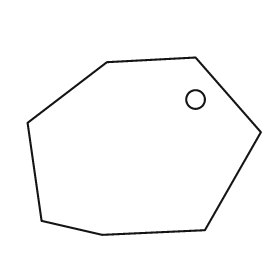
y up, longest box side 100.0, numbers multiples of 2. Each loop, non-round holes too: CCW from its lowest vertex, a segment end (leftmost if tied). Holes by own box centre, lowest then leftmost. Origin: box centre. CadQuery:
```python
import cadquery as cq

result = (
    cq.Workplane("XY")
    .moveTo(-18.0, -38.0)
    .lineTo(26.0, -36.0)
    .lineTo(50.0, 6.0)
    .lineTo(22.0, 38.0)
    .lineTo(-16.0, 36.0)
    .lineTo(-50.0, 10.0)
    .lineTo(-44.0, -32.0)
    .close()
    .moveTo(22.0, 20.0)
    .circle(4.0)
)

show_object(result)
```